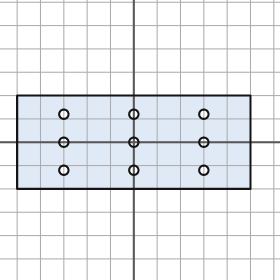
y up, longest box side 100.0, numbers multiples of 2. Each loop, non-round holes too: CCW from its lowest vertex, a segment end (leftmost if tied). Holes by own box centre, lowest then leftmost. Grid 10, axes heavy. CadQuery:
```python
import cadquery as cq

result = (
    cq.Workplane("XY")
    .moveTo(-50.0, -20.0)
    .lineTo(50.0, -20.0)
    .lineTo(50.0, 20.0)
    .lineTo(-50.0, 20.0)
    .close()
    .moveTo(-30.0, -12.0)
    .circle(2.0)
    .moveTo(0.0, -12.0)
    .circle(2.0)
    .moveTo(30.0, -12.0)
    .circle(2.0)
    .moveTo(-30.0, 0.0)
    .circle(2.0)
    .moveTo(0.0, 0.0)
    .circle(2.0)
    .moveTo(30.0, 0.0)
    .circle(2.0)
    .moveTo(-30.0, 12.0)
    .circle(2.0)
    .moveTo(0.0, 12.0)
    .circle(2.0)
    .moveTo(30.0, 12.0)
    .circle(2.0)
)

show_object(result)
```